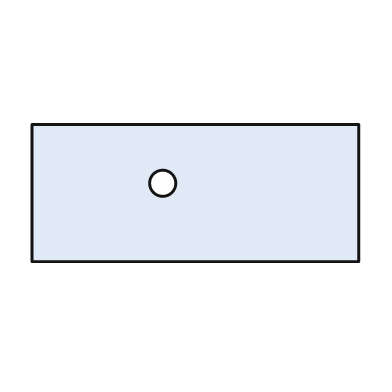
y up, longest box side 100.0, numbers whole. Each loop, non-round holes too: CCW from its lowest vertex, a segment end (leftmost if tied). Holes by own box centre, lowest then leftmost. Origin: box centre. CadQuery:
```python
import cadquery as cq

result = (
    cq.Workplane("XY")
    .moveTo(-50.0, -21.0)
    .lineTo(50.0, -21.0)
    .lineTo(50.0, 21.0)
    .lineTo(-50.0, 21.0)
    .close()
    .moveTo(-10.0, 3.0)
    .circle(4.0)
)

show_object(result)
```